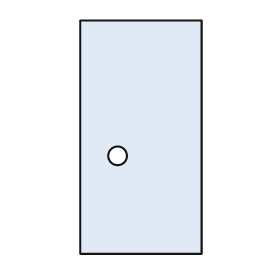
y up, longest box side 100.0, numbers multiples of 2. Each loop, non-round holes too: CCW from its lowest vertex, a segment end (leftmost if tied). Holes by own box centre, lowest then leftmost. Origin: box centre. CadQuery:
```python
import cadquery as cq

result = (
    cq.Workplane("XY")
    .moveTo(-26.0, -50.0)
    .lineTo(26.0, -50.0)
    .lineTo(26.0, 50.0)
    .lineTo(-26.0, 50.0)
    .close()
    .moveTo(-10.0, -8.0)
    .circle(4.0)
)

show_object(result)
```